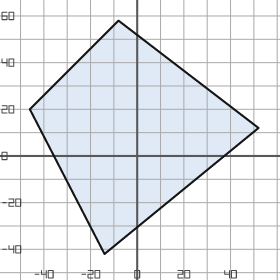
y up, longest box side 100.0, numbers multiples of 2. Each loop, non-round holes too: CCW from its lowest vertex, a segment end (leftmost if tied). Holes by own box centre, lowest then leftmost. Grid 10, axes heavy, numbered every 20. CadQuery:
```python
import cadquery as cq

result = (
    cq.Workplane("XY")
    .moveTo(-14.0, -42.0)
    .lineTo(52.0, 12.0)
    .lineTo(-8.0, 58.0)
    .lineTo(-46.0, 20.0)
    .close()
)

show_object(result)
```